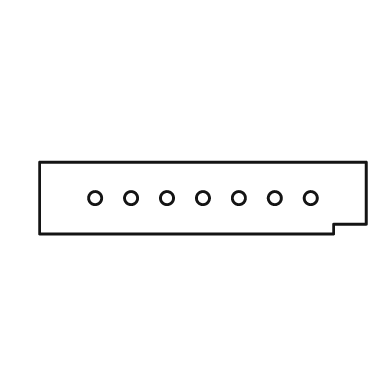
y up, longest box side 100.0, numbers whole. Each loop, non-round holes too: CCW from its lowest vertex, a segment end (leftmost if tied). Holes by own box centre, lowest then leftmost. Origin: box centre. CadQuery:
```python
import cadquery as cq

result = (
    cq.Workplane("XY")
    .moveTo(-50.0, -11.0)
    .lineTo(40.0, -11.0)
    .lineTo(40.0, -8.0)
    .lineTo(50.0, -8.0)
    .lineTo(50.0, 11.0)
    .lineTo(-50.0, 11.0)
    .close()
    .moveTo(-33.0, 0.0)
    .circle(2.0)
    .moveTo(-22.0, 0.0)
    .circle(2.0)
    .moveTo(-11.0, 0.0)
    .circle(2.0)
    .moveTo(0.0, 0.0)
    .circle(2.0)
    .moveTo(11.0, 0.0)
    .circle(2.0)
    .moveTo(22.0, 0.0)
    .circle(2.0)
    .moveTo(33.0, 0.0)
    .circle(2.0)
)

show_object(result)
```